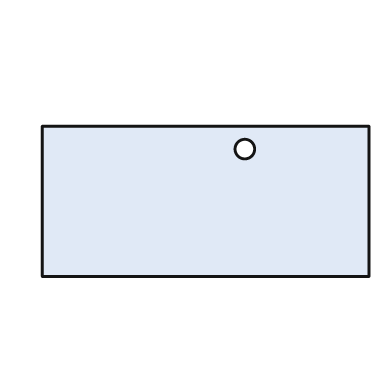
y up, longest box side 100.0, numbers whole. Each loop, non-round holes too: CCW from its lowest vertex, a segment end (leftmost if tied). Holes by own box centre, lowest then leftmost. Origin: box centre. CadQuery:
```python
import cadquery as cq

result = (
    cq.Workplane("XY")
    .moveTo(-50.0, -23.0)
    .lineTo(50.0, -23.0)
    .lineTo(50.0, 23.0)
    .lineTo(-50.0, 23.0)
    .close()
    .moveTo(12.0, 16.0)
    .circle(3.0)
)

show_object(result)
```